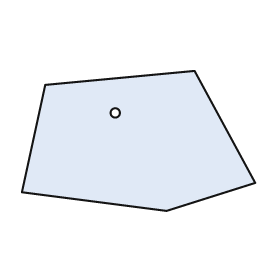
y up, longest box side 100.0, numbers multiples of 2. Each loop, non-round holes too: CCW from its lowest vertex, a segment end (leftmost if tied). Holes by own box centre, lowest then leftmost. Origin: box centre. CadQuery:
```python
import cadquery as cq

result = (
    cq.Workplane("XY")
    .moveTo(12.0, -30.0)
    .lineTo(50.0, -18.0)
    .lineTo(24.0, 30.0)
    .lineTo(-40.0, 24.0)
    .lineTo(-50.0, -22.0)
    .close()
    .moveTo(-10.0, 12.0)
    .circle(2.0)
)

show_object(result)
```